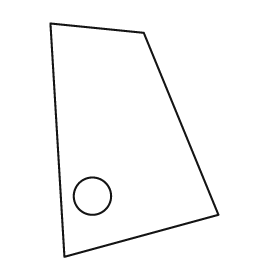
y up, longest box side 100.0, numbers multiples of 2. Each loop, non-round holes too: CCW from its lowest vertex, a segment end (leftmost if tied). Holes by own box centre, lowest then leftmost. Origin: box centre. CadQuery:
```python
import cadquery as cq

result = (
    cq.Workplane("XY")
    .moveTo(-30.0, -50.0)
    .lineTo(36.0, -32.0)
    .lineTo(4.0, 46.0)
    .lineTo(-36.0, 50.0)
    .close()
    .moveTo(-18.0, -24.0)
    .circle(8.0)
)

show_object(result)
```